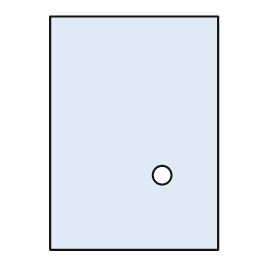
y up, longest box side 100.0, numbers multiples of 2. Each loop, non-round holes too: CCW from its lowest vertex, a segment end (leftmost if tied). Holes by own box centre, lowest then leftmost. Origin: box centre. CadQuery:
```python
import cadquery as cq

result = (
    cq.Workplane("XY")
    .moveTo(-36.0, -50.0)
    .lineTo(36.0, -50.0)
    .lineTo(36.0, 50.0)
    .lineTo(-36.0, 50.0)
    .close()
    .moveTo(12.0, -18.0)
    .circle(4.0)
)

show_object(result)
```